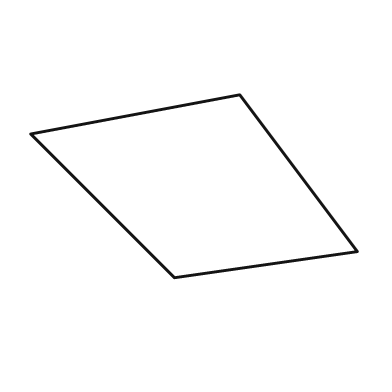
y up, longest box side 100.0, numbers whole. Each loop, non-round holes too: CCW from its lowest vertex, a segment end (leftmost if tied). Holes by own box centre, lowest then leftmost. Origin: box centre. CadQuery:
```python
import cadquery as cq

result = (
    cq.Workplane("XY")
    .moveTo(-6.0, -28.0)
    .lineTo(50.0, -20.0)
    .lineTo(14.0, 28.0)
    .lineTo(-50.0, 16.0)
    .close()
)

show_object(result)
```